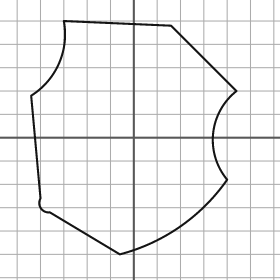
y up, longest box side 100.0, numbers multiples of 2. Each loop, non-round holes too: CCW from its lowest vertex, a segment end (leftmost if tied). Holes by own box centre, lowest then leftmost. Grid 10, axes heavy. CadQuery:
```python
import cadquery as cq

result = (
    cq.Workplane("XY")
    .moveTo(-6.0, -50.0)
    .threePointArc((20.0, -38.0), (40.0, -18.0))
    .threePointArc((34.0, 2.0), (44.0, 20.0))
    .lineTo(16.0, 48.0)
    .lineTo(-30.0, 50.0)
    .threePointArc((-32.0, 32.0), (-44.0, 18.0))
    .lineTo(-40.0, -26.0)
    .threePointArc((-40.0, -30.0), (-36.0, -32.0))
    .close()
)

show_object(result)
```